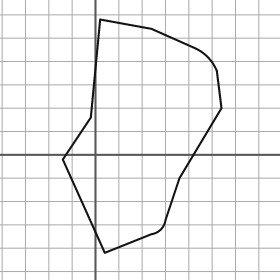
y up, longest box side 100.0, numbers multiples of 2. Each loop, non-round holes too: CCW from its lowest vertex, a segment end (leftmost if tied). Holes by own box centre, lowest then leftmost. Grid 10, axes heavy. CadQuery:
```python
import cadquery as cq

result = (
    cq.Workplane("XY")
    .moveTo(4.0, -42.0)
    .lineTo(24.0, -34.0)
    .threePointArc((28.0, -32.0), (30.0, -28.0))
    .lineTo(36.0, -10.0)
    .lineTo(54.0, 20.0)
    .lineTo(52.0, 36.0)
    .threePointArc((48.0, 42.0), (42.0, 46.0))
    .lineTo(24.0, 54.0)
    .lineTo(2.0, 58.0)
    .lineTo(-2.0, 16.0)
    .lineTo(-14.0, -2.0)
    .close()
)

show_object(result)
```